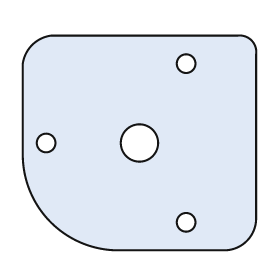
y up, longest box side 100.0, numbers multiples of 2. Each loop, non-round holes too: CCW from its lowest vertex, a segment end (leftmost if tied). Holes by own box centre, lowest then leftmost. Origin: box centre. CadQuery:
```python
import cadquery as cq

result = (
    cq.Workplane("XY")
    .moveTo(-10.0, -46.0)
    .lineTo(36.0, -46.0)
    .threePointArc((46.0, -42.0), (50.0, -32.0))
    .lineTo(50.0, 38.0)
    .threePointArc((48.0, 44.0), (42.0, 46.0))
    .lineTo(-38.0, 46.0)
    .threePointArc((-46.0, 42.0), (-50.0, 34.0))
    .lineTo(-50.0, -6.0)
    .threePointArc((-38.0, -34.0), (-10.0, -46.0))
    .close()
    .moveTo(20.0, -34.0)
    .circle(4.0)
    .moveTo(-40.0, 0.0)
    .circle(4.0)
    .moveTo(0.0, 0.0)
    .circle(8.0)
    .moveTo(20.0, 34.0)
    .circle(4.0)
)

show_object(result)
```